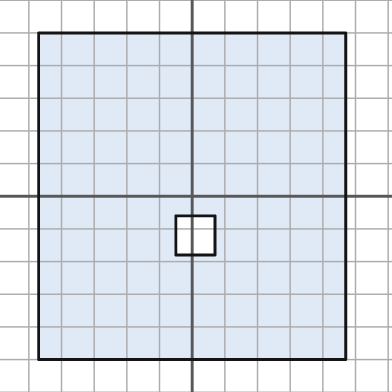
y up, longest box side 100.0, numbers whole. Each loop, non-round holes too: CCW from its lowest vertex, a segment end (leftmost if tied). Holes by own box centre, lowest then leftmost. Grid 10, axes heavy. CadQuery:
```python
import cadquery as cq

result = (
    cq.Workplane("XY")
    .moveTo(-47.0, -50.0)
    .lineTo(47.0, -50.0)
    .lineTo(47.0, 50.0)
    .lineTo(-47.0, 50.0)
    .close()
    .moveTo(-5.0, -18.0)
    .lineTo(7.0, -18.0)
    .lineTo(7.0, -6.0)
    .lineTo(-5.0, -6.0)
    .close()
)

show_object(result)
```